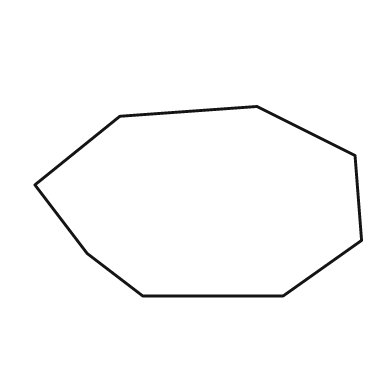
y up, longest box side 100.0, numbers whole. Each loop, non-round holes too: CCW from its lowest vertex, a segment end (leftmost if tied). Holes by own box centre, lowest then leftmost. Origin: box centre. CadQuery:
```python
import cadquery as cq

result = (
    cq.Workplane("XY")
    .moveTo(-17.0, -29.0)
    .lineTo(26.0, -29.0)
    .lineTo(50.0, -12.0)
    .lineTo(48.0, 14.0)
    .lineTo(18.0, 29.0)
    .lineTo(-24.0, 26.0)
    .lineTo(-50.0, 5.0)
    .lineTo(-34.0, -16.0)
    .close()
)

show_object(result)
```